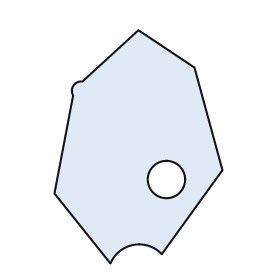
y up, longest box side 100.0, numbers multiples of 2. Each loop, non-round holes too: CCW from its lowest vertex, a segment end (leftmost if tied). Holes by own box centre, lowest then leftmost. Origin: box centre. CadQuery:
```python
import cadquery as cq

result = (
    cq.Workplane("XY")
    .moveTo(-12.0, -50.0)
    .threePointArc((-2.0, -42.0), (10.0, -46.0))
    .lineTo(36.0, -10.0)
    .lineTo(24.0, 34.0)
    .lineTo(0.0, 50.0)
    .lineTo(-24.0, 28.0)
    .threePointArc((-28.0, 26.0), (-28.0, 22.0))
    .lineTo(-36.0, -20.0)
    .close()
    .moveTo(12.0, -14.0)
    .circle(8.0)
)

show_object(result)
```